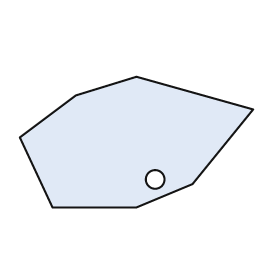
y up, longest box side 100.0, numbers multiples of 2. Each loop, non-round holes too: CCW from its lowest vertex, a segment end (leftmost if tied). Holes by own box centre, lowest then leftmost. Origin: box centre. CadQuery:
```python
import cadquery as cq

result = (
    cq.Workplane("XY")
    .moveTo(-36.0, -28.0)
    .lineTo(0.0, -28.0)
    .lineTo(24.0, -18.0)
    .lineTo(50.0, 14.0)
    .lineTo(0.0, 28.0)
    .lineTo(-26.0, 20.0)
    .lineTo(-50.0, 2.0)
    .close()
    .moveTo(8.0, -16.0)
    .circle(4.0)
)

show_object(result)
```